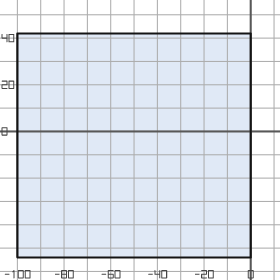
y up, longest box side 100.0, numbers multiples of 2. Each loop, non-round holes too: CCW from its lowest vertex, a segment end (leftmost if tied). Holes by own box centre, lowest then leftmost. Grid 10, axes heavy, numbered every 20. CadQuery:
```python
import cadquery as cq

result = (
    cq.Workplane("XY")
    .moveTo(-100.0, -54.0)
    .lineTo(0.0, -54.0)
    .lineTo(0.0, 42.0)
    .lineTo(-100.0, 42.0)
    .close()
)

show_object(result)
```